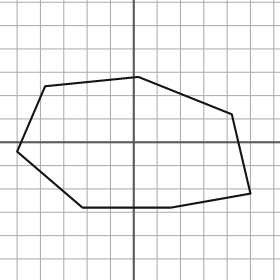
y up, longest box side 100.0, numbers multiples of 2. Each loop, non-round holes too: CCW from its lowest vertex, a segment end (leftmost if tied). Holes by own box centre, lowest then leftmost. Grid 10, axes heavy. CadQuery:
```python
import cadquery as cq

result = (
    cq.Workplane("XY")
    .moveTo(-22.0, -28.0)
    .lineTo(16.0, -28.0)
    .lineTo(50.0, -22.0)
    .lineTo(42.0, 12.0)
    .lineTo(2.0, 28.0)
    .lineTo(-38.0, 24.0)
    .lineTo(-50.0, -4.0)
    .close()
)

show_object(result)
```